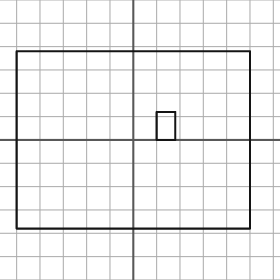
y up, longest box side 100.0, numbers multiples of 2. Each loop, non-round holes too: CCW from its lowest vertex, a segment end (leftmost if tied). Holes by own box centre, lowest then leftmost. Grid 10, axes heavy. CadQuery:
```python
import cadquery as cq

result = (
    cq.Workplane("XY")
    .moveTo(-50.0, -38.0)
    .lineTo(50.0, -38.0)
    .lineTo(50.0, 38.0)
    .lineTo(-50.0, 38.0)
    .close()
    .moveTo(10.0, 0.0)
    .lineTo(18.0, 0.0)
    .lineTo(18.0, 12.0)
    .lineTo(10.0, 12.0)
    .close()
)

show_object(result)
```